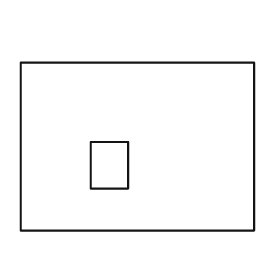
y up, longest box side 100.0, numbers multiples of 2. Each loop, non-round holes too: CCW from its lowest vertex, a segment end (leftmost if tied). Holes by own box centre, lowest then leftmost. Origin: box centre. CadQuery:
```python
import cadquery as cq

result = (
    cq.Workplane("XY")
    .moveTo(-50.0, -36.0)
    .lineTo(50.0, -36.0)
    .lineTo(50.0, 36.0)
    .lineTo(-50.0, 36.0)
    .close()
    .moveTo(-20.0, -18.0)
    .lineTo(-4.0, -18.0)
    .lineTo(-4.0, 2.0)
    .lineTo(-20.0, 2.0)
    .close()
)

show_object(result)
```